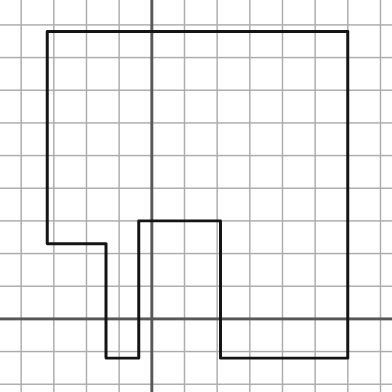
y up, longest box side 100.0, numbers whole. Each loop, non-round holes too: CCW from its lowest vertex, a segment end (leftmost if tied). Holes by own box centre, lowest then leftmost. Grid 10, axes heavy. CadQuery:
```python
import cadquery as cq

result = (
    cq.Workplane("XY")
    .moveTo(-14.0, -12.0)
    .lineTo(-4.0, -12.0)
    .lineTo(-4.0, 30.0)
    .lineTo(21.0, 30.0)
    .lineTo(21.0, -12.0)
    .lineTo(60.0, -12.0)
    .lineTo(60.0, 88.0)
    .lineTo(-32.0, 88.0)
    .lineTo(-32.0, 23.0)
    .lineTo(-14.0, 23.0)
    .close()
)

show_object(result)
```